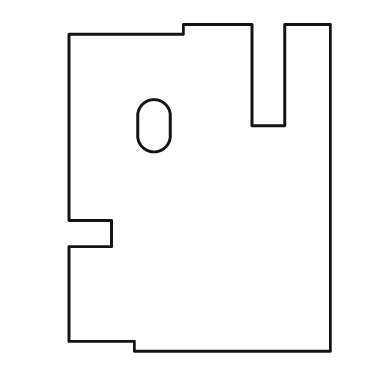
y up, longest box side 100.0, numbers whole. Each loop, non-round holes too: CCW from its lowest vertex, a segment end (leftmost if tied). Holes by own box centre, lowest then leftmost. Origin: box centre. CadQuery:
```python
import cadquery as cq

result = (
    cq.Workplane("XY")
    .moveTo(-20.0, -50.0)
    .lineTo(40.0, -50.0)
    .lineTo(40.0, 50.0)
    .lineTo(26.0, 50.0)
    .lineTo(26.0, 19.0)
    .lineTo(16.0, 19.0)
    .lineTo(16.0, 50.0)
    .lineTo(-5.0, 50.0)
    .lineTo(-5.0, 47.0)
    .lineTo(-40.0, 47.0)
    .lineTo(-40.0, -10.0)
    .lineTo(-27.0, -10.0)
    .lineTo(-27.0, -18.0)
    .lineTo(-40.0, -18.0)
    .lineTo(-40.0, -47.0)
    .lineTo(-20.0, -47.0)
    .close()
    .moveTo(-19.0, 16.0)
    .threePointArc((-14.0, 11.0), (-9.0, 16.0))
    .lineTo(-9.0, 22.0)
    .threePointArc((-14.0, 27.0), (-19.0, 22.0))
    .close()
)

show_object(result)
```